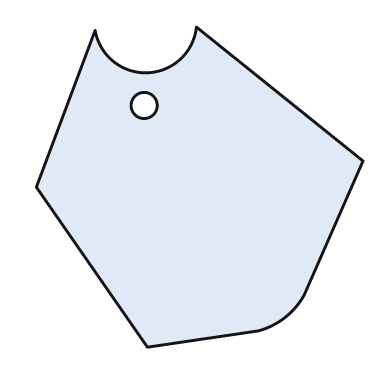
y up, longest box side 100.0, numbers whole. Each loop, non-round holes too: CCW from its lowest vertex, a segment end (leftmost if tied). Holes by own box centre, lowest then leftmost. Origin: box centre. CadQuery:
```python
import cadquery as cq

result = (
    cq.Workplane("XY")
    .moveTo(-16.0, -49.0)
    .lineTo(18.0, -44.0)
    .threePointArc((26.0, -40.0), (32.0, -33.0))
    .lineTo(50.0, 8.0)
    .lineTo(-1.0, 49.0)
    .threePointArc((-16.0, 35.0), (-32.0, 48.0))
    .lineTo(-50.0, 0.0)
    .close()
    .moveTo(-17.0, 25.0)
    .circle(4.0)
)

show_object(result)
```